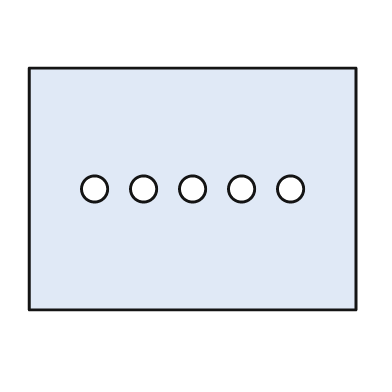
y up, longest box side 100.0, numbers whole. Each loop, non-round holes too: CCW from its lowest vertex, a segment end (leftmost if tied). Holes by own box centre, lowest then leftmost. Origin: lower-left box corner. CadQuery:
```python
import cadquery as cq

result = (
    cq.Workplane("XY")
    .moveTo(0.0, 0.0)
    .lineTo(100.0, 0.0)
    .lineTo(100.0, 74.0)
    .lineTo(0.0, 74.0)
    .close()
    .moveTo(20.0, 37.0)
    .circle(4.0)
    .moveTo(35.0, 37.0)
    .circle(4.0)
    .moveTo(50.0, 37.0)
    .circle(4.0)
    .moveTo(65.0, 37.0)
    .circle(4.0)
    .moveTo(80.0, 37.0)
    .circle(4.0)
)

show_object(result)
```